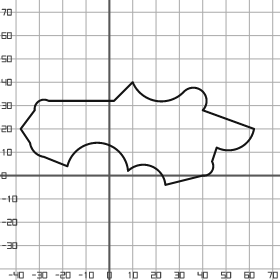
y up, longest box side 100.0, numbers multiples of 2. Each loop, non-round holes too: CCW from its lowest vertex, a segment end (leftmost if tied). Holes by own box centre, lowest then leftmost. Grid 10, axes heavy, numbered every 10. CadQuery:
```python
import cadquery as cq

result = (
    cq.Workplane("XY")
    .moveTo(24.0, -4.0)
    .lineTo(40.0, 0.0)
    .threePointArc((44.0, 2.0), (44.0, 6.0))
    .lineTo(46.0, 12.0)
    .threePointArc((56.0, 12.0), (62.0, 20.0))
    .lineTo(40.0, 28.0)
    .threePointArc((40.0, 36.0), (32.0, 36.0))
    .threePointArc((20.0, 32.0), (10.0, 40.0))
    .lineTo(2.0, 32.0)
    .lineTo(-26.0, 32.0)
    .threePointArc((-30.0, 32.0), (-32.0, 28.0))
    .lineTo(-38.0, 20.0)
    .lineTo(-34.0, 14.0)
    .threePointArc((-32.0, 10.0), (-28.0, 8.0))
    .lineTo(-18.0, 4.0)
    .threePointArc((-4.0, 14.0), (8.0, 2.0))
    .threePointArc((18.0, 4.0), (24.0, -4.0))
    .close()
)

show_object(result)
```